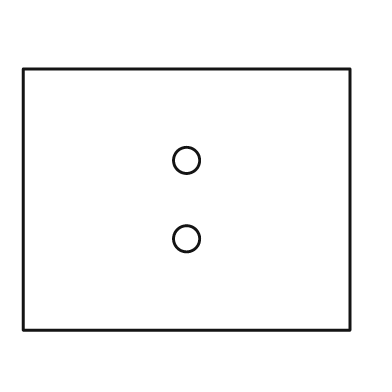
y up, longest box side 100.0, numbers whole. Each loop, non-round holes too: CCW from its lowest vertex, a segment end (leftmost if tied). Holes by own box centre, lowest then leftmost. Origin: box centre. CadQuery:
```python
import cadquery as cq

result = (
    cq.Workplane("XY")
    .moveTo(-50.0, -40.0)
    .lineTo(50.0, -40.0)
    .lineTo(50.0, 40.0)
    .lineTo(-50.0, 40.0)
    .close()
    .moveTo(0.0, -12.0)
    .circle(4.0)
    .moveTo(0.0, 12.0)
    .circle(4.0)
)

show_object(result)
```